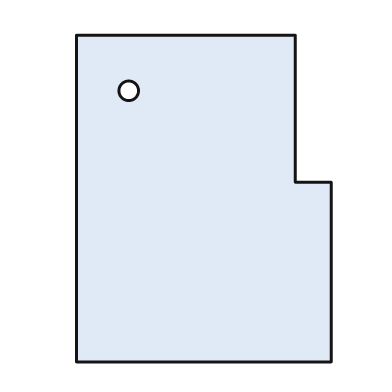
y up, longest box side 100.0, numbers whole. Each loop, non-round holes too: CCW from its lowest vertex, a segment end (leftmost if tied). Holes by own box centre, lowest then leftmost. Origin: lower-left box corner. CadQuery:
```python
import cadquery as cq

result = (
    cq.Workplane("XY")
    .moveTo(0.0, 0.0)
    .lineTo(78.0, 0.0)
    .lineTo(78.0, 55.0)
    .lineTo(67.0, 55.0)
    .lineTo(67.0, 100.0)
    .lineTo(0.0, 100.0)
    .close()
    .moveTo(16.0, 83.0)
    .circle(3.0)
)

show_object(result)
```